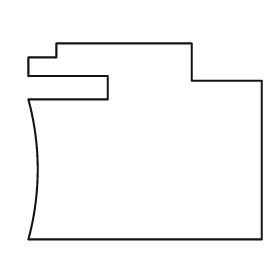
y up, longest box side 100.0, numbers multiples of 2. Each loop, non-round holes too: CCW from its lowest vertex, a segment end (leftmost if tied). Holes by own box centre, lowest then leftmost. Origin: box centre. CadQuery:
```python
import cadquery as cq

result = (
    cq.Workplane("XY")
    .moveTo(-50.0, -42.0)
    .lineTo(50.0, -42.0)
    .lineTo(50.0, 26.0)
    .lineTo(20.0, 26.0)
    .lineTo(20.0, 42.0)
    .lineTo(-38.0, 42.0)
    .lineTo(-38.0, 36.0)
    .lineTo(-50.0, 36.0)
    .lineTo(-50.0, 28.0)
    .lineTo(-16.0, 28.0)
    .lineTo(-16.0, 18.0)
    .lineTo(-50.0, 18.0)
    .threePointArc((-46.0, -12.0), (-50.0, -42.0))
    .close()
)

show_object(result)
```